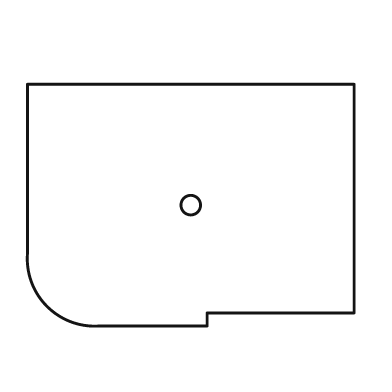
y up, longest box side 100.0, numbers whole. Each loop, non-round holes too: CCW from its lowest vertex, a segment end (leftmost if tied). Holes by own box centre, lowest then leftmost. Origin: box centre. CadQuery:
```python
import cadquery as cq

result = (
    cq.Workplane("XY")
    .moveTo(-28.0, -37.0)
    .lineTo(5.0, -37.0)
    .lineTo(5.0, -33.0)
    .lineTo(50.0, -33.0)
    .lineTo(50.0, 37.0)
    .lineTo(-50.0, 37.0)
    .lineTo(-50.0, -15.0)
    .threePointArc((-44.0, -31.0), (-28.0, -37.0))
    .close()
    .moveTo(0.0, 0.0)
    .circle(3.0)
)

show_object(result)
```